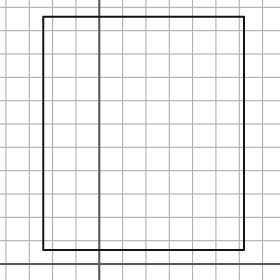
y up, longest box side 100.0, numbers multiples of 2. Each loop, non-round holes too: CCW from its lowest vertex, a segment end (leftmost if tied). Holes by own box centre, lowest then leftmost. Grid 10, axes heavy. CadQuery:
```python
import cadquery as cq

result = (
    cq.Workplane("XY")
    .moveTo(-24.0, 6.0)
    .lineTo(62.0, 6.0)
    .lineTo(62.0, 106.0)
    .lineTo(-24.0, 106.0)
    .close()
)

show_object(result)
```